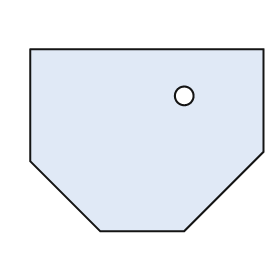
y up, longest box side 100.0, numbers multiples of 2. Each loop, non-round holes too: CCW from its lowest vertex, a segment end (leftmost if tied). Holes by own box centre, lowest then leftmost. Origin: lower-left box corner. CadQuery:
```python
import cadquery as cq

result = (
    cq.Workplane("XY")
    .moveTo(30.0, 0.0)
    .lineTo(66.0, 0.0)
    .lineTo(100.0, 34.0)
    .lineTo(100.0, 78.0)
    .lineTo(0.0, 78.0)
    .lineTo(0.0, 30.0)
    .close()
    .moveTo(66.0, 58.0)
    .circle(4.0)
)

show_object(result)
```